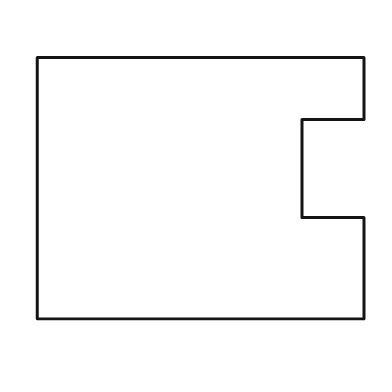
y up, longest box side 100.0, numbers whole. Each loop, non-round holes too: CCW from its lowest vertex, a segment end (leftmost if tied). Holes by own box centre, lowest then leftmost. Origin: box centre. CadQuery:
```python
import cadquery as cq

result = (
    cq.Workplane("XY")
    .moveTo(-50.0, -40.0)
    .lineTo(50.0, -40.0)
    .lineTo(50.0, -9.0)
    .lineTo(31.0, -9.0)
    .lineTo(31.0, 21.0)
    .lineTo(50.0, 21.0)
    .lineTo(50.0, 40.0)
    .lineTo(-50.0, 40.0)
    .close()
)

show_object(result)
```